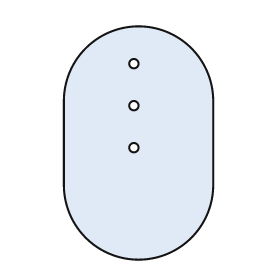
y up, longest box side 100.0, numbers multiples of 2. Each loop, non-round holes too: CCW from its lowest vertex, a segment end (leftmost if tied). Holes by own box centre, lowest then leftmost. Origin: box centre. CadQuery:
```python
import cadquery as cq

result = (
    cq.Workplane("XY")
    .moveTo(-32.0, -18.0)
    .threePointArc((0.0, -50.0), (32.0, -18.0))
    .lineTo(32.0, 18.0)
    .threePointArc((0.0, 50.0), (-32.0, 18.0))
    .close()
    .moveTo(-2.0, -2.0)
    .circle(2.0)
    .moveTo(-2.0, 16.0)
    .circle(2.0)
    .moveTo(-2.0, 34.0)
    .circle(2.0)
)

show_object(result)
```